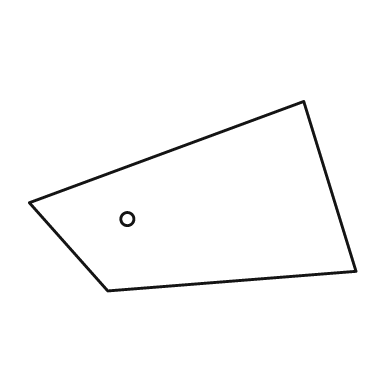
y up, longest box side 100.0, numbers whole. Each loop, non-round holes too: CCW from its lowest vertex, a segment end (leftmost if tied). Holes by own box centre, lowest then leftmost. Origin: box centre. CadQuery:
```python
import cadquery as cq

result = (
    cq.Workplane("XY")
    .moveTo(-26.0, -29.0)
    .lineTo(50.0, -23.0)
    .lineTo(34.0, 29.0)
    .lineTo(-50.0, -2.0)
    .close()
    .moveTo(-20.0, -7.0)
    .circle(2.0)
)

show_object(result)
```